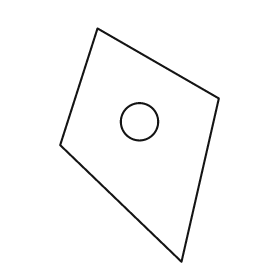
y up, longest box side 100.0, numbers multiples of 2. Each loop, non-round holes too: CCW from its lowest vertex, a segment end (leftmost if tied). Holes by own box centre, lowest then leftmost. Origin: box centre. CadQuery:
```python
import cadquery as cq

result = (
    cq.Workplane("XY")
    .moveTo(18.0, -50.0)
    .lineTo(34.0, 20.0)
    .lineTo(-18.0, 50.0)
    .lineTo(-34.0, 0.0)
    .close()
    .moveTo(0.0, 10.0)
    .circle(8.0)
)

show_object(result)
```